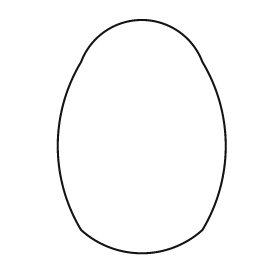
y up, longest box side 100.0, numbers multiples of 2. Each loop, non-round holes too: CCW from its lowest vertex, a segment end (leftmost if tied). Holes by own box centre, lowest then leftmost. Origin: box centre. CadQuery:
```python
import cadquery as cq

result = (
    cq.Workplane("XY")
    .moveTo(-26.0, -40.0)
    .threePointArc((0.0, -50.0), (26.0, -40.0))
    .threePointArc((36.0, -4.0), (26.0, 32.0))
    .threePointArc((0.0, 50.0), (-26.0, 32.0))
    .threePointArc((-36.0, -4.0), (-26.0, -40.0))
    .close()
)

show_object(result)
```